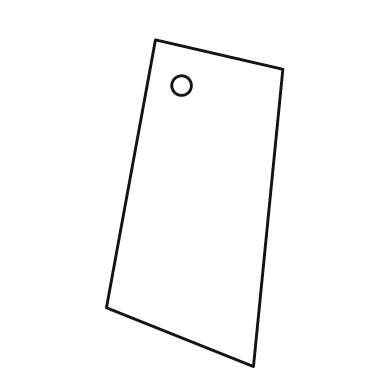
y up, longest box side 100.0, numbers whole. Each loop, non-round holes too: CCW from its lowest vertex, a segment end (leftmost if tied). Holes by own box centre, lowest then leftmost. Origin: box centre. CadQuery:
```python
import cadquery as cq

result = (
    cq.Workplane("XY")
    .moveTo(18.0, -50.0)
    .lineTo(27.0, 41.0)
    .lineTo(-12.0, 50.0)
    .lineTo(-27.0, -32.0)
    .close()
    .moveTo(-4.0, 36.0)
    .circle(3.0)
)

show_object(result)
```